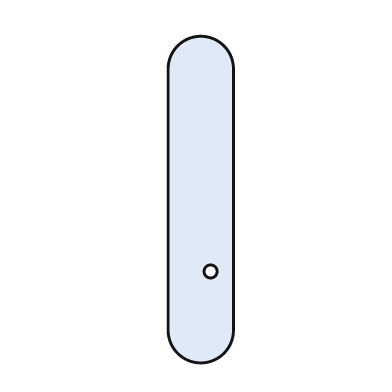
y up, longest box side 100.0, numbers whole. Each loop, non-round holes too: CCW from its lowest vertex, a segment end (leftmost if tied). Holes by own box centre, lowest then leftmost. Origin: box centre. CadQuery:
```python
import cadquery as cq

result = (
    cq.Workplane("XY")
    .moveTo(-10.0, -40.0)
    .threePointArc((0.0, -50.0), (10.0, -40.0))
    .lineTo(10.0, 40.0)
    .threePointArc((0.0, 50.0), (-10.0, 40.0))
    .close()
    .moveTo(3.0, -22.0)
    .circle(2.0)
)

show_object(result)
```